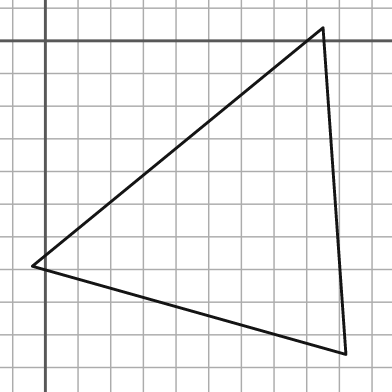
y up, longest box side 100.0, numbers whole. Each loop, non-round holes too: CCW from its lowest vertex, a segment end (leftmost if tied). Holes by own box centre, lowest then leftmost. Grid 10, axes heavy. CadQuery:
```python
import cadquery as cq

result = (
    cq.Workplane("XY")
    .moveTo(92.0, -96.0)
    .lineTo(85.0, 4.0)
    .lineTo(-4.0, -69.0)
    .close()
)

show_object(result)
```